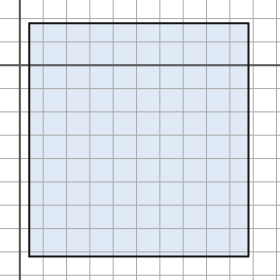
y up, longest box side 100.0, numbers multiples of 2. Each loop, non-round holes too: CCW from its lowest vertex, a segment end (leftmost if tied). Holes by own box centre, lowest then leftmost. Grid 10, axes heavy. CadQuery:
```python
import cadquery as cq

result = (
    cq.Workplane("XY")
    .moveTo(4.0, -82.0)
    .lineTo(98.0, -82.0)
    .lineTo(98.0, 18.0)
    .lineTo(4.0, 18.0)
    .close()
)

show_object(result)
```